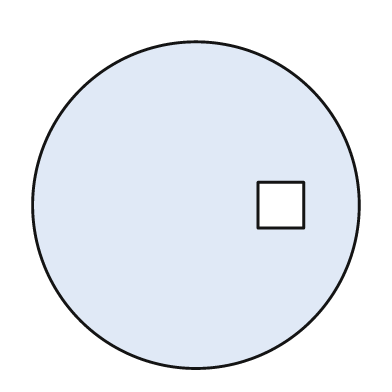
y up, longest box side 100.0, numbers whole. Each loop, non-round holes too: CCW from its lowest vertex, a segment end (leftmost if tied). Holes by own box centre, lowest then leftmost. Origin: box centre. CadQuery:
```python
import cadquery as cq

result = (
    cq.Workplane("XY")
    .moveTo(0.0, 0.0)
    .circle(50.0)
    .moveTo(19.0, -7.0)
    .lineTo(33.0, -7.0)
    .lineTo(33.0, 7.0)
    .lineTo(19.0, 7.0)
    .close()
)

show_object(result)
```